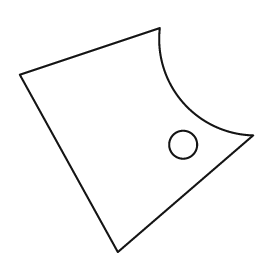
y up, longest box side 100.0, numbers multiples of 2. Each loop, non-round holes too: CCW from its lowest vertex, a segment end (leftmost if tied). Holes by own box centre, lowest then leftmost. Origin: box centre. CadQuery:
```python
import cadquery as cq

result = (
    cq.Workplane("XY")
    .moveTo(-8.0, -48.0)
    .lineTo(50.0, 2.0)
    .threePointArc((20.0, 16.0), (10.0, 48.0))
    .lineTo(-50.0, 28.0)
    .close()
    .moveTo(20.0, -2.0)
    .circle(6.0)
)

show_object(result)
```